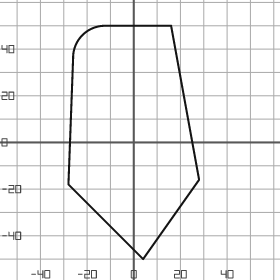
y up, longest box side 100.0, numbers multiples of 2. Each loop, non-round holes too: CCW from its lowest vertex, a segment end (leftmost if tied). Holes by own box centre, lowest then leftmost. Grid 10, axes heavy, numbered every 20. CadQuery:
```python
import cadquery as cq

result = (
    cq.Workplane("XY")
    .moveTo(4.0, -50.0)
    .lineTo(28.0, -16.0)
    .lineTo(16.0, 50.0)
    .lineTo(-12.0, 50.0)
    .threePointArc((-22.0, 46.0), (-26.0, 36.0))
    .lineTo(-28.0, -18.0)
    .close()
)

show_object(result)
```